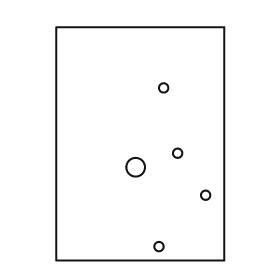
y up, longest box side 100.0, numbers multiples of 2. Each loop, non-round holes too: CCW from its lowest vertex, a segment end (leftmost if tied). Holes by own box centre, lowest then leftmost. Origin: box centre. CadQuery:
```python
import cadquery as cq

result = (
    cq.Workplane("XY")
    .moveTo(-36.0, -50.0)
    .lineTo(36.0, -50.0)
    .lineTo(36.0, 50.0)
    .lineTo(-36.0, 50.0)
    .close()
    .moveTo(8.0, -44.0)
    .circle(2.0)
    .moveTo(28.0, -22.0)
    .circle(2.0)
    .moveTo(-2.0, -10.0)
    .circle(4.0)
    .moveTo(16.0, -4.0)
    .circle(2.0)
    .moveTo(10.0, 24.0)
    .circle(2.0)
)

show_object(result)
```